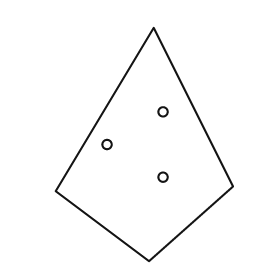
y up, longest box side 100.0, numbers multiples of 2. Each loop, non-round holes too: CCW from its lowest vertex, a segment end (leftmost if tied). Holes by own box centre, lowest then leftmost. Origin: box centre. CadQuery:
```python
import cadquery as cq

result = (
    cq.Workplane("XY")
    .moveTo(2.0, -50.0)
    .lineTo(38.0, -18.0)
    .lineTo(4.0, 50.0)
    .lineTo(-38.0, -20.0)
    .close()
    .moveTo(8.0, -14.0)
    .circle(2.0)
    .moveTo(-16.0, 0.0)
    .circle(2.0)
    .moveTo(8.0, 14.0)
    .circle(2.0)
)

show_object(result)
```